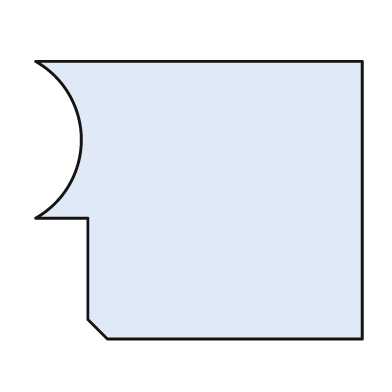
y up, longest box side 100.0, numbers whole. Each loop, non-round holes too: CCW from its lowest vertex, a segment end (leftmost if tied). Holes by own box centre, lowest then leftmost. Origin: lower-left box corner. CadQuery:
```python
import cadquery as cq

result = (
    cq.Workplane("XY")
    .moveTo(22.0, 0.0)
    .lineTo(100.0, 0.0)
    .lineTo(100.0, 85.0)
    .lineTo(0.0, 85.0)
    .threePointArc((14.0, 61.0), (0.0, 37.0))
    .lineTo(16.0, 37.0)
    .lineTo(16.0, 6.0)
    .close()
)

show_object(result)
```